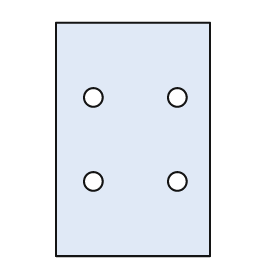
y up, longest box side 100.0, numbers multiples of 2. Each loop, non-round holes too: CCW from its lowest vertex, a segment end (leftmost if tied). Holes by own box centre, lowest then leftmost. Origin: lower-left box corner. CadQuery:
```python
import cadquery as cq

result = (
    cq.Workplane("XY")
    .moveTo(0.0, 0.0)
    .lineTo(66.0, 0.0)
    .lineTo(66.0, 100.0)
    .lineTo(0.0, 100.0)
    .close()
    .moveTo(16.0, 32.0)
    .circle(4.0)
    .moveTo(52.0, 32.0)
    .circle(4.0)
    .moveTo(16.0, 68.0)
    .circle(4.0)
    .moveTo(52.0, 68.0)
    .circle(4.0)
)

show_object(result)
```